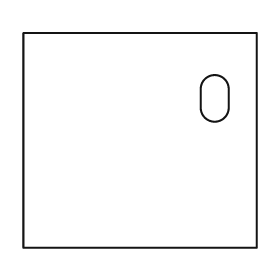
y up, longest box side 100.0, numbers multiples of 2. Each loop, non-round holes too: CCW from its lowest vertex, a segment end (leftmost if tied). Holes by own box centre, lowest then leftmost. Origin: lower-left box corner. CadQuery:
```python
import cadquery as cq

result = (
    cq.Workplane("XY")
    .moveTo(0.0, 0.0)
    .lineTo(100.0, 0.0)
    .lineTo(100.0, 92.0)
    .lineTo(0.0, 92.0)
    .close()
    .moveTo(76.0, 60.0)
    .threePointArc((82.0, 54.0), (88.0, 60.0))
    .lineTo(88.0, 68.0)
    .threePointArc((82.0, 74.0), (76.0, 68.0))
    .close()
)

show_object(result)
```